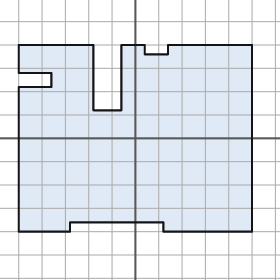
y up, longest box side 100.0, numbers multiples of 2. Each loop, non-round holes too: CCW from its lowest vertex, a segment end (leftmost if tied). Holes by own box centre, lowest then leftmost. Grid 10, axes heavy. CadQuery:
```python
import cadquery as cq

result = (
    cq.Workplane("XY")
    .moveTo(-50.0, -40.0)
    .lineTo(-28.0, -40.0)
    .lineTo(-28.0, -36.0)
    .lineTo(12.0, -36.0)
    .lineTo(12.0, -40.0)
    .lineTo(50.0, -40.0)
    .lineTo(50.0, 40.0)
    .lineTo(14.0, 40.0)
    .lineTo(14.0, 36.0)
    .lineTo(4.0, 36.0)
    .lineTo(4.0, 40.0)
    .lineTo(-6.0, 40.0)
    .lineTo(-6.0, 12.0)
    .lineTo(-18.0, 12.0)
    .lineTo(-18.0, 40.0)
    .lineTo(-50.0, 40.0)
    .lineTo(-50.0, 28.0)
    .lineTo(-36.0, 28.0)
    .lineTo(-36.0, 22.0)
    .lineTo(-50.0, 22.0)
    .close()
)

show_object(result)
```